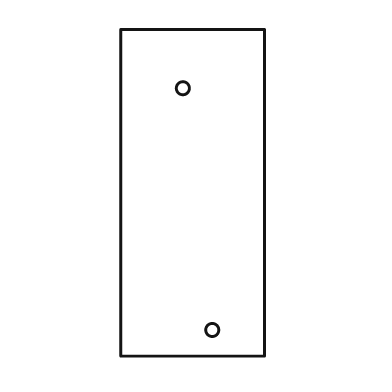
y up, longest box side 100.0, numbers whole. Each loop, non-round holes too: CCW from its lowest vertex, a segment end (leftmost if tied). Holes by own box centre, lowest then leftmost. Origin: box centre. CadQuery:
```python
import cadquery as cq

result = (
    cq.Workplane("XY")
    .moveTo(-22.0, -50.0)
    .lineTo(22.0, -50.0)
    .lineTo(22.0, 50.0)
    .lineTo(-22.0, 50.0)
    .close()
    .moveTo(6.0, -42.0)
    .circle(2.0)
    .moveTo(-3.0, 32.0)
    .circle(2.0)
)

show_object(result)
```